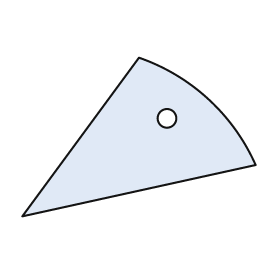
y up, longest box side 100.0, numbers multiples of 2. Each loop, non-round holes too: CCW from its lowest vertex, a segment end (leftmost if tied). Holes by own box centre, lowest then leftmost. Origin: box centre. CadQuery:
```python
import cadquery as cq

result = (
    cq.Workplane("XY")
    .moveTo(-50.0, -34.0)
    .lineTo(50.0, -12.0)
    .threePointArc((30.0, 16.0), (0.0, 34.0))
    .close()
    .moveTo(12.0, 8.0)
    .circle(4.0)
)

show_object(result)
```